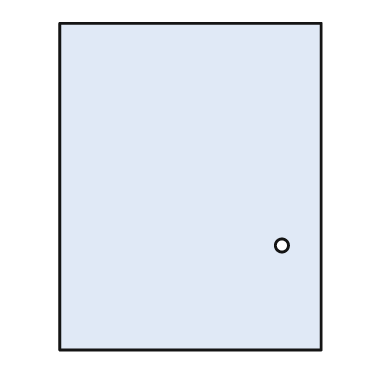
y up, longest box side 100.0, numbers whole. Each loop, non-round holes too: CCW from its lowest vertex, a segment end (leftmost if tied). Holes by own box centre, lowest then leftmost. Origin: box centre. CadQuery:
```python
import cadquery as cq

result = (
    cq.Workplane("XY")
    .moveTo(-40.0, -50.0)
    .lineTo(40.0, -50.0)
    .lineTo(40.0, 50.0)
    .lineTo(-40.0, 50.0)
    .close()
    .moveTo(28.0, -18.0)
    .circle(2.0)
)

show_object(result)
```